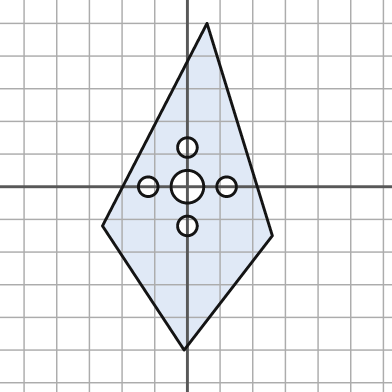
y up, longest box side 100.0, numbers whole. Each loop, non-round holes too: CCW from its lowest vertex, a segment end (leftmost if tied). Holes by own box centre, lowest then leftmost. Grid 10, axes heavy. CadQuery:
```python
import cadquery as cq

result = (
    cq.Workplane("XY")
    .moveTo(-1.0, -50.0)
    .lineTo(26.0, -15.0)
    .lineTo(6.0, 50.0)
    .lineTo(-26.0, -12.0)
    .close()
    .moveTo(0.0, -12.0)
    .circle(3.0)
    .moveTo(-12.0, 0.0)
    .circle(3.0)
    .moveTo(0.0, 0.0)
    .circle(5.0)
    .moveTo(12.0, 0.0)
    .circle(3.0)
    .moveTo(0.0, 12.0)
    .circle(3.0)
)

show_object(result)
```